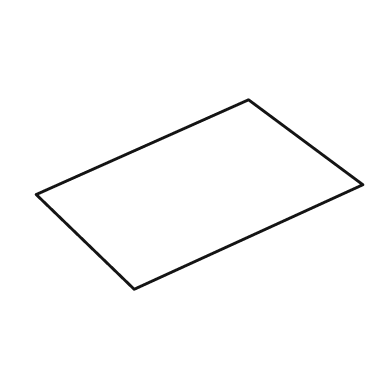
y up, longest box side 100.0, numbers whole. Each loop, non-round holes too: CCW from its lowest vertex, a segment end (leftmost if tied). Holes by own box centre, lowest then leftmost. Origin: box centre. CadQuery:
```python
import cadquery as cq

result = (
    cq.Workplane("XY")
    .moveTo(-20.0, -29.0)
    .lineTo(50.0, 3.0)
    .lineTo(15.0, 29.0)
    .lineTo(-50.0, 0.0)
    .close()
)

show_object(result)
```